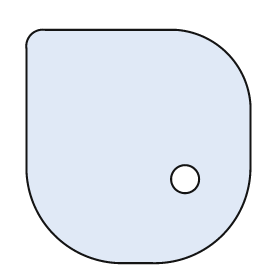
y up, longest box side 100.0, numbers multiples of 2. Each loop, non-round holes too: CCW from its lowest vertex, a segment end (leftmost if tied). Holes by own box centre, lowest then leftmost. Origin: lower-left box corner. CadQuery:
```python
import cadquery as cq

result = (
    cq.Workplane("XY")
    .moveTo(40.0, 0.0)
    .lineTo(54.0, 0.0)
    .threePointArc((84.0, 12.0), (96.0, 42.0))
    .lineTo(96.0, 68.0)
    .threePointArc((86.0, 90.0), (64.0, 100.0))
    .lineTo(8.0, 100.0)
    .threePointArc((2.0, 98.0), (0.0, 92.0))
    .lineTo(0.0, 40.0)
    .threePointArc((12.0, 12.0), (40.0, 0.0))
    .close()
    .moveTo(68.0, 36.0)
    .circle(6.0)
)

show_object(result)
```